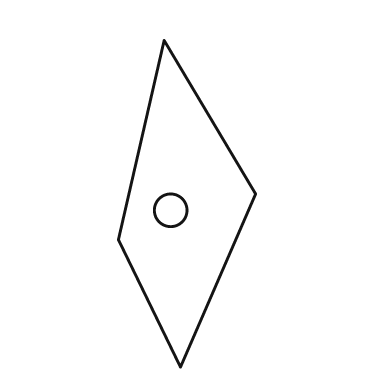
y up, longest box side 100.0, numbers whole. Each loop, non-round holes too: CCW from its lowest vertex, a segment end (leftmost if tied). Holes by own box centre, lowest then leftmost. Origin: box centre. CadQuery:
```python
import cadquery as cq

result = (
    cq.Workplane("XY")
    .moveTo(-2.0, -50.0)
    .lineTo(21.0, 3.0)
    .lineTo(-7.0, 50.0)
    .lineTo(-21.0, -11.0)
    .close()
    .moveTo(-5.0, -2.0)
    .circle(5.0)
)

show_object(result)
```